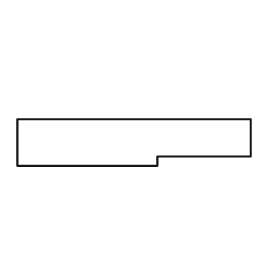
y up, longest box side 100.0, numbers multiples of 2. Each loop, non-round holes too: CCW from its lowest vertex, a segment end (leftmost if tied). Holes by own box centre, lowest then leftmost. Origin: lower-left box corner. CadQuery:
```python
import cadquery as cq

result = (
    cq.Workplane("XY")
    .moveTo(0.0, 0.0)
    .lineTo(60.0, 0.0)
    .lineTo(60.0, 4.0)
    .lineTo(100.0, 4.0)
    .lineTo(100.0, 20.0)
    .lineTo(0.0, 20.0)
    .close()
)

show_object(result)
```